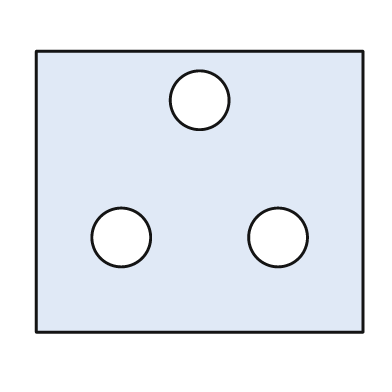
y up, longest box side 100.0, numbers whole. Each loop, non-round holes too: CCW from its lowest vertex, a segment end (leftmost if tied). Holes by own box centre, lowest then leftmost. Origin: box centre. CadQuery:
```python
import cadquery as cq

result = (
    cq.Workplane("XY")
    .moveTo(-50.0, -43.0)
    .lineTo(50.0, -43.0)
    .lineTo(50.0, 43.0)
    .lineTo(-50.0, 43.0)
    .close()
    .moveTo(-24.0, -14.0)
    .circle(9.0)
    .moveTo(24.0, -14.0)
    .circle(9.0)
    .moveTo(0.0, 28.0)
    .circle(9.0)
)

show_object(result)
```